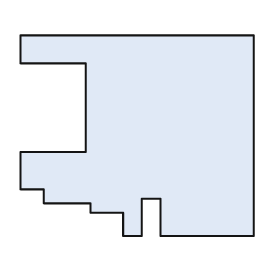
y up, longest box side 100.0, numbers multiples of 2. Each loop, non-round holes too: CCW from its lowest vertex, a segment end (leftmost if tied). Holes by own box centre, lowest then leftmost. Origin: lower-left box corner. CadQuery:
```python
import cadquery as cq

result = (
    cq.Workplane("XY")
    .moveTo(44.0, 0.0)
    .lineTo(52.0, 0.0)
    .lineTo(52.0, 16.0)
    .lineTo(60.0, 16.0)
    .lineTo(60.0, 0.0)
    .lineTo(100.0, 0.0)
    .lineTo(100.0, 86.0)
    .lineTo(0.0, 86.0)
    .lineTo(0.0, 74.0)
    .lineTo(28.0, 74.0)
    .lineTo(28.0, 36.0)
    .lineTo(0.0, 36.0)
    .lineTo(0.0, 20.0)
    .lineTo(10.0, 20.0)
    .lineTo(10.0, 14.0)
    .lineTo(30.0, 14.0)
    .lineTo(30.0, 10.0)
    .lineTo(44.0, 10.0)
    .close()
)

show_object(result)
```